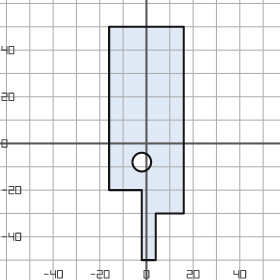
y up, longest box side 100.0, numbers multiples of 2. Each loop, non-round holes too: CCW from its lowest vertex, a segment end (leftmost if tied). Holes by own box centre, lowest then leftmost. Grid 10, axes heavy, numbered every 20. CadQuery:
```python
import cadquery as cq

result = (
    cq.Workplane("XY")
    .moveTo(-2.0, -50.0)
    .lineTo(4.0, -50.0)
    .lineTo(4.0, -30.0)
    .lineTo(16.0, -30.0)
    .lineTo(16.0, 50.0)
    .lineTo(-16.0, 50.0)
    .lineTo(-16.0, -20.0)
    .lineTo(-2.0, -20.0)
    .close()
    .moveTo(-2.0, -8.0)
    .circle(4.0)
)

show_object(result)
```